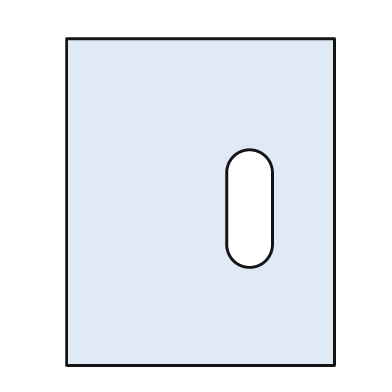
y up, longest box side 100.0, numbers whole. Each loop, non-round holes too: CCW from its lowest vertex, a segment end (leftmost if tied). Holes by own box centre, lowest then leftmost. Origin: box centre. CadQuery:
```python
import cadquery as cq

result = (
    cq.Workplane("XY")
    .moveTo(-41.0, -50.0)
    .lineTo(41.0, -50.0)
    .lineTo(41.0, 50.0)
    .lineTo(-41.0, 50.0)
    .close()
    .moveTo(8.0, -13.0)
    .threePointArc((15.0, -20.0), (22.0, -13.0))
    .lineTo(22.0, 9.0)
    .threePointArc((15.0, 16.0), (8.0, 9.0))
    .close()
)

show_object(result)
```